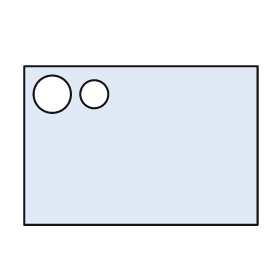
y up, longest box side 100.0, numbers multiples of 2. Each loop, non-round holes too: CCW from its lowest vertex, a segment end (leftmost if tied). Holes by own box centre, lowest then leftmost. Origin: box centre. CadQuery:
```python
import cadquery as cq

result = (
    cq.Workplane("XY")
    .moveTo(-50.0, -34.0)
    .lineTo(50.0, -34.0)
    .lineTo(50.0, 34.0)
    .lineTo(-50.0, 34.0)
    .close()
    .moveTo(-38.0, 22.0)
    .circle(8.0)
    .moveTo(-20.0, 22.0)
    .circle(6.0)
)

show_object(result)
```